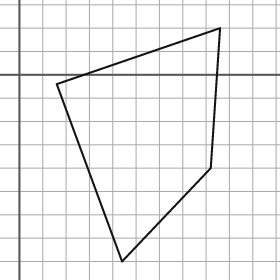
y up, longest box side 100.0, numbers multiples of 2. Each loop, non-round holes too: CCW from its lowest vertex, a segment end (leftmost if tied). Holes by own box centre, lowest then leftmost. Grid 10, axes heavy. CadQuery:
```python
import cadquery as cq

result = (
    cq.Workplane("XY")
    .moveTo(44.0, -80.0)
    .lineTo(82.0, -40.0)
    .lineTo(86.0, 20.0)
    .lineTo(16.0, -4.0)
    .close()
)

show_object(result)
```